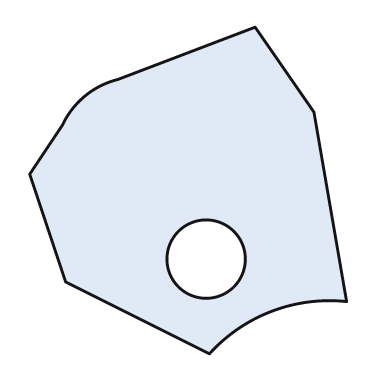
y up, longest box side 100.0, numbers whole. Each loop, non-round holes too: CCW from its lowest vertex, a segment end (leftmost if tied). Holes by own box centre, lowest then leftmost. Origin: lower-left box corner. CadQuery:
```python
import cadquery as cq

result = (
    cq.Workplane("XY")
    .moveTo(55.0, 0.0)
    .threePointArc((74.0, 13.0), (97.0, 16.0))
    .lineTo(87.0, 74.0)
    .lineTo(69.0, 100.0)
    .lineTo(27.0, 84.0)
    .threePointArc((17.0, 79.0), (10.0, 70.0))
    .lineTo(0.0, 55.0)
    .lineTo(11.0, 22.0)
    .close()
    .moveTo(54.0, 29.0)
    .circle(12.0)
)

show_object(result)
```